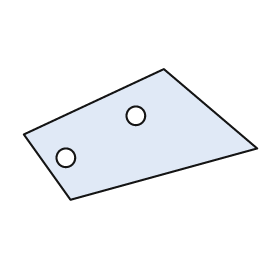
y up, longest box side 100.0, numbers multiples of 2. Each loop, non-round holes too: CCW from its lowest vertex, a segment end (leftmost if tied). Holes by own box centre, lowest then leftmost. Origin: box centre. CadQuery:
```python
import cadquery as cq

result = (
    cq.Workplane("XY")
    .moveTo(-30.0, -28.0)
    .lineTo(50.0, -6.0)
    .lineTo(10.0, 28.0)
    .lineTo(-50.0, 0.0)
    .close()
    .moveTo(-32.0, -10.0)
    .circle(4.0)
    .moveTo(-2.0, 8.0)
    .circle(4.0)
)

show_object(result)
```